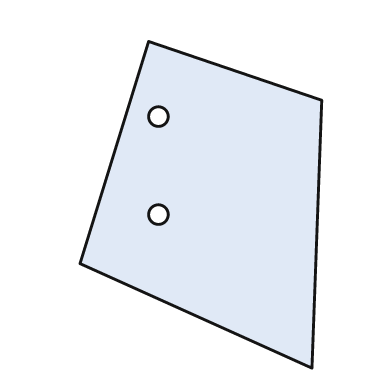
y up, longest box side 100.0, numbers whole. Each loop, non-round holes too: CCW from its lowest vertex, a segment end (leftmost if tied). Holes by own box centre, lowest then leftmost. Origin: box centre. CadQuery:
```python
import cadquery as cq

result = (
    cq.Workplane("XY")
    .moveTo(34.0, -50.0)
    .lineTo(37.0, 32.0)
    .lineTo(-16.0, 50.0)
    .lineTo(-37.0, -18.0)
    .close()
    .moveTo(-13.0, -3.0)
    .circle(3.0)
    .moveTo(-13.0, 27.0)
    .circle(3.0)
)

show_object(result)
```